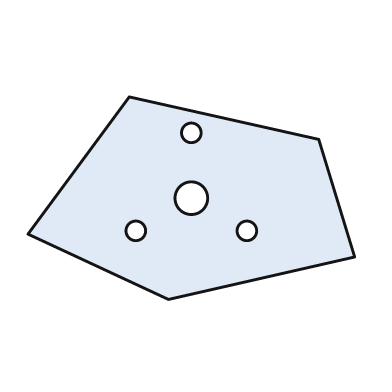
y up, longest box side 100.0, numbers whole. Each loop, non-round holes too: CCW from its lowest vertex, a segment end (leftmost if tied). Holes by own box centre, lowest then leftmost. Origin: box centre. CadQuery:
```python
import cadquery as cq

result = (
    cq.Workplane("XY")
    .moveTo(-7.0, -31.0)
    .lineTo(50.0, -18.0)
    .lineTo(39.0, 18.0)
    .lineTo(-19.0, 31.0)
    .lineTo(-50.0, -11.0)
    .close()
    .moveTo(-17.0, -10.0)
    .circle(3.0)
    .moveTo(17.0, -10.0)
    .circle(3.0)
    .moveTo(0.0, 0.0)
    .circle(5.0)
    .moveTo(0.0, 20.0)
    .circle(3.0)
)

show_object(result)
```